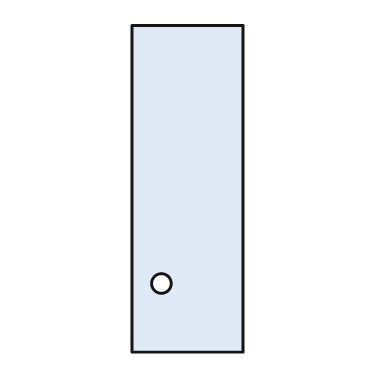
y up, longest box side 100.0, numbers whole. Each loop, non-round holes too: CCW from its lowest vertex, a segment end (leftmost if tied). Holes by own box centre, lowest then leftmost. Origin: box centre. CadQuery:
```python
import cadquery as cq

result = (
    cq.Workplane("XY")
    .moveTo(-17.0, -50.0)
    .lineTo(17.0, -50.0)
    .lineTo(17.0, 50.0)
    .lineTo(-17.0, 50.0)
    .close()
    .moveTo(-8.0, -29.0)
    .circle(3.0)
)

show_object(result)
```